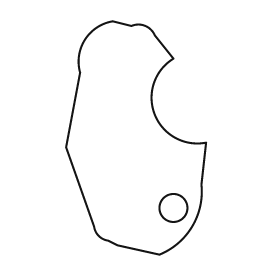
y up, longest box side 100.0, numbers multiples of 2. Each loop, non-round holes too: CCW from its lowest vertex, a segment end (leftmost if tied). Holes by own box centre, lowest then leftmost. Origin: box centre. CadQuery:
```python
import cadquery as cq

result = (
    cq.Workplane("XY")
    .moveTo(10.0, -50.0)
    .threePointArc((24.0, -38.0), (28.0, -20.0))
    .lineTo(30.0, -2.0)
    .threePointArc((8.0, 10.0), (16.0, 34.0))
    .lineTo(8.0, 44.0)
    .threePointArc((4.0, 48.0), (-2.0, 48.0))
    .lineTo(-10.0, 50.0)
    .threePointArc((-22.0, 42.0), (-24.0, 28.0))
    .lineTo(-30.0, -4.0)
    .lineTo(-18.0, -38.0)
    .threePointArc((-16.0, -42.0), (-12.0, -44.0))
    .lineTo(-8.0, -46.0)
    .close()
    .moveTo(16.0, -30.0)
    .circle(6.0)
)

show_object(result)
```